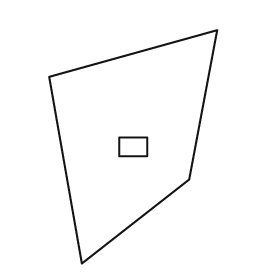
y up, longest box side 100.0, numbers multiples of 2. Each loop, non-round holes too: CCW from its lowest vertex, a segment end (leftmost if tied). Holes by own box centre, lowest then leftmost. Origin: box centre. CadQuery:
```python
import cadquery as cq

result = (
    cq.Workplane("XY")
    .moveTo(-22.0, -50.0)
    .lineTo(24.0, -14.0)
    .lineTo(36.0, 50.0)
    .lineTo(-36.0, 30.0)
    .close()
    .moveTo(-6.0, -4.0)
    .lineTo(6.0, -4.0)
    .lineTo(6.0, 4.0)
    .lineTo(-6.0, 4.0)
    .close()
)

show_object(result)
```